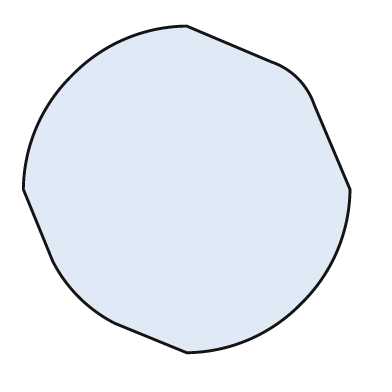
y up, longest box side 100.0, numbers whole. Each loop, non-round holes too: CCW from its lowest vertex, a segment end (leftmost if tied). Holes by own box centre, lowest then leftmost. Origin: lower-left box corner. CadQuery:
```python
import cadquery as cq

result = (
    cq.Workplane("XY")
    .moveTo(50.0, 0.0)
    .threePointArc((69.0, 4.0), (85.0, 15.0))
    .threePointArc((96.0, 31.0), (100.0, 50.0))
    .lineTo(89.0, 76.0)
    .threePointArc((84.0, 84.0), (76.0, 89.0))
    .lineTo(50.0, 100.0)
    .threePointArc((31.0, 96.0), (15.0, 85.0))
    .threePointArc((4.0, 69.0), (0.0, 50.0))
    .lineTo(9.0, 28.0)
    .threePointArc((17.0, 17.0), (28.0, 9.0))
    .close()
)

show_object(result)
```